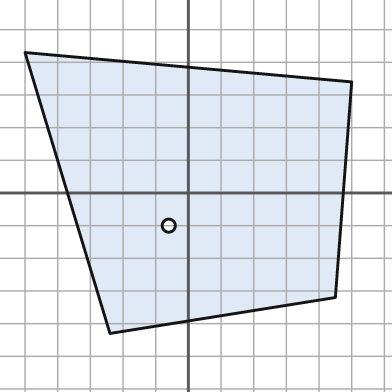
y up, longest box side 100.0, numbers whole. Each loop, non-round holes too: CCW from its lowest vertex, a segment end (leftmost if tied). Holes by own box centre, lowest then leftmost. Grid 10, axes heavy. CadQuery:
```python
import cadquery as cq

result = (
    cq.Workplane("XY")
    .moveTo(-24.0, -43.0)
    .lineTo(45.0, -32.0)
    .lineTo(50.0, 34.0)
    .lineTo(-50.0, 43.0)
    .close()
    .moveTo(-6.0, -10.0)
    .circle(2.0)
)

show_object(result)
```